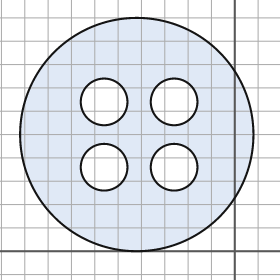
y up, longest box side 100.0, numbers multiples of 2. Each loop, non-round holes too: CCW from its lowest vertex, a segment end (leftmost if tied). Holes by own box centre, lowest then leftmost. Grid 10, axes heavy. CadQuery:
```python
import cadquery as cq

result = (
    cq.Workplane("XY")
    .moveTo(-42.0, 50.0)
    .circle(50.0)
    .moveTo(-56.0, 36.0)
    .circle(10.0)
    .moveTo(-26.0, 36.0)
    .circle(10.0)
    .moveTo(-56.0, 64.0)
    .circle(10.0)
    .moveTo(-26.0, 64.0)
    .circle(10.0)
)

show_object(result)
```